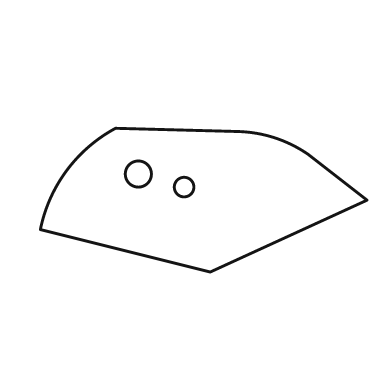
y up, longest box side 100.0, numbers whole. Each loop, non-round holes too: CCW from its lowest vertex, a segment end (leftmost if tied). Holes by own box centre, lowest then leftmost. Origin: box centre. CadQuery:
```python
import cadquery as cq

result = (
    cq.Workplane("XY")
    .moveTo(2.0, -22.0)
    .lineTo(50.0, 0.0)
    .lineTo(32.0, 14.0)
    .threePointArc((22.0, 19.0), (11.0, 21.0))
    .lineTo(-27.0, 22.0)
    .threePointArc((-42.0, 9.0), (-50.0, -9.0))
    .close()
    .moveTo(-6.0, 4.0)
    .circle(3.0)
    .moveTo(-20.0, 8.0)
    .circle(4.0)
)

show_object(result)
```